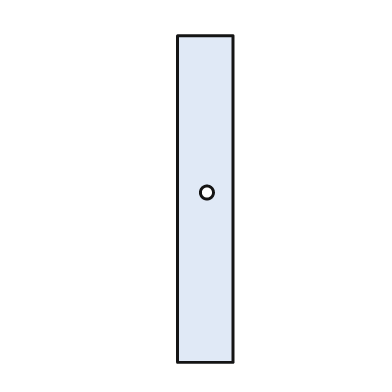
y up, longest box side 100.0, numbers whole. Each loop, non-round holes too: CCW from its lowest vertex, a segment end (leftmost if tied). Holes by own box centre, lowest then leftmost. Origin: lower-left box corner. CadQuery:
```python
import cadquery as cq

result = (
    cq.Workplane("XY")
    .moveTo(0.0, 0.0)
    .lineTo(17.0, 0.0)
    .lineTo(17.0, 100.0)
    .lineTo(0.0, 100.0)
    .close()
    .moveTo(9.0, 52.0)
    .circle(2.0)
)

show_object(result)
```